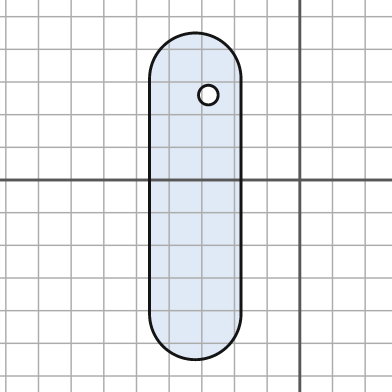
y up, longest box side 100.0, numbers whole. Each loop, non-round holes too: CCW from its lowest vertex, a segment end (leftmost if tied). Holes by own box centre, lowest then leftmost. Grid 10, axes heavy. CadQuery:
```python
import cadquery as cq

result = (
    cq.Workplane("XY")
    .moveTo(-46.0, -41.0)
    .threePointArc((-32.0, -55.0), (-18.0, -41.0))
    .lineTo(-18.0, 31.0)
    .threePointArc((-32.0, 45.0), (-46.0, 31.0))
    .close()
    .moveTo(-28.0, 26.0)
    .circle(3.0)
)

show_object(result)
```